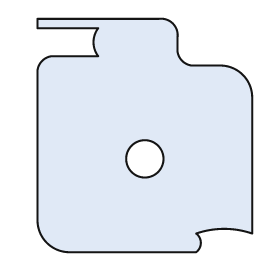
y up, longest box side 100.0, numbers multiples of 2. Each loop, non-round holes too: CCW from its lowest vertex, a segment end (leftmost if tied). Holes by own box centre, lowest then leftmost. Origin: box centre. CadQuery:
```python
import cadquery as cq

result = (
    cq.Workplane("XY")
    .moveTo(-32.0, -50.0)
    .lineTo(22.0, -50.0)
    .threePointArc((24.0, -46.0), (22.0, -42.0))
    .threePointArc((34.0, -40.0), (46.0, -42.0))
    .lineTo(46.0, 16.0)
    .threePointArc((42.0, 26.0), (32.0, 30.0))
    .lineTo(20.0, 30.0)
    .threePointArc((16.0, 32.0), (14.0, 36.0))
    .lineTo(14.0, 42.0)
    .threePointArc((12.0, 48.0), (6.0, 50.0))
    .lineTo(-46.0, 50.0)
    .lineTo(-46.0, 46.0)
    .lineTo(-20.0, 46.0)
    .threePointArc((-22.0, 40.0), (-20.0, 34.0))
    .lineTo(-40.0, 34.0)
    .threePointArc((-44.0, 32.0), (-46.0, 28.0))
    .lineTo(-46.0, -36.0)
    .threePointArc((-42.0, -46.0), (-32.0, -50.0))
    .close()
    .moveTo(0.0, -10.0)
    .circle(8.0)
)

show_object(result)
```